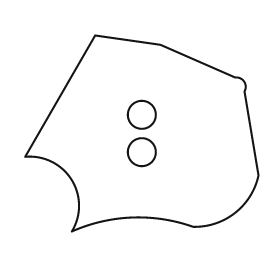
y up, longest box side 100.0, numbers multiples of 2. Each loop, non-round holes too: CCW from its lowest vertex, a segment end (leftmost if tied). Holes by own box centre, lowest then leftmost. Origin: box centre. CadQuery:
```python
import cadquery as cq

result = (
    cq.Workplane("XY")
    .moveTo(-30.0, -42.0)
    .threePointArc((-4.0, -36.0), (22.0, -40.0))
    .threePointArc((40.0, -34.0), (50.0, -18.0))
    .lineTo(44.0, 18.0)
    .threePointArc((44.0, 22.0), (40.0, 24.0))
    .lineTo(8.0, 38.0)
    .lineTo(-20.0, 42.0)
    .lineTo(-50.0, -10.0)
    .threePointArc((-30.0, -20.0), (-30.0, -42.0))
    .close()
    .moveTo(0.0, -8.0)
    .circle(6.0)
    .moveTo(0.0, 8.0)
    .circle(6.0)
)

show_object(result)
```